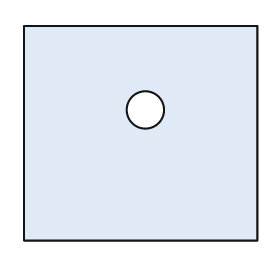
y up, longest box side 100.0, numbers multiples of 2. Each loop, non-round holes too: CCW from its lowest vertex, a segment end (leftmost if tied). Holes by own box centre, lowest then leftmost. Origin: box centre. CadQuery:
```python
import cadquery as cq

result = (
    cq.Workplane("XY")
    .moveTo(-50.0, -46.0)
    .lineTo(50.0, -46.0)
    .lineTo(50.0, 46.0)
    .lineTo(-50.0, 46.0)
    .close()
    .moveTo(2.0, 10.0)
    .circle(8.0)
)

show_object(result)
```